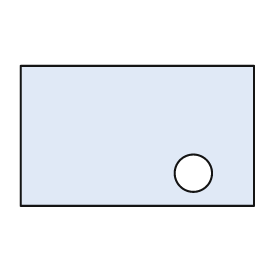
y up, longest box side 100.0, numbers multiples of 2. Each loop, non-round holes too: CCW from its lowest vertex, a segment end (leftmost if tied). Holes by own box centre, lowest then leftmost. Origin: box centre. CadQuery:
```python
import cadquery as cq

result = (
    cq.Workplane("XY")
    .moveTo(-50.0, -30.0)
    .lineTo(50.0, -30.0)
    .lineTo(50.0, 30.0)
    .lineTo(-50.0, 30.0)
    .close()
    .moveTo(24.0, -16.0)
    .circle(8.0)
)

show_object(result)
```